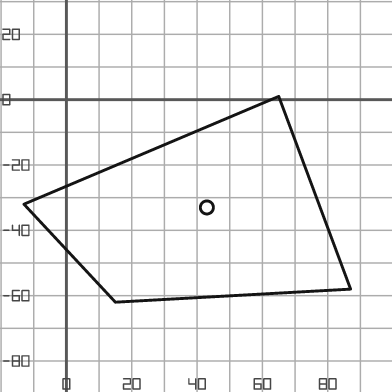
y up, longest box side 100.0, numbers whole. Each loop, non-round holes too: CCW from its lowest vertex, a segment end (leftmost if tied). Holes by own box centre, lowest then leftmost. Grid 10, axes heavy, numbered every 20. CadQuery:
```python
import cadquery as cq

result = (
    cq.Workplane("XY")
    .moveTo(15.0, -62.0)
    .lineTo(87.0, -58.0)
    .lineTo(65.0, 1.0)
    .lineTo(-13.0, -32.0)
    .close()
    .moveTo(43.0, -33.0)
    .circle(2.0)
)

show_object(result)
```